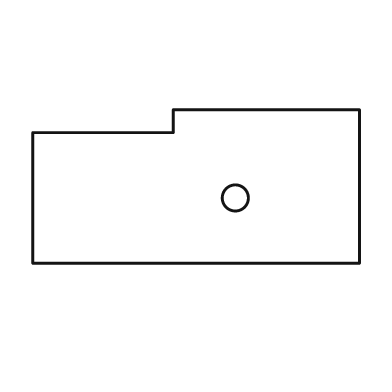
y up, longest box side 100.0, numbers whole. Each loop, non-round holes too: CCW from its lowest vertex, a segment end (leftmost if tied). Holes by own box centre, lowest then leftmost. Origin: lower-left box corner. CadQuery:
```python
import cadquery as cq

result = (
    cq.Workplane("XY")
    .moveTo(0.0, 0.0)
    .lineTo(100.0, 0.0)
    .lineTo(100.0, 47.0)
    .lineTo(43.0, 47.0)
    .lineTo(43.0, 40.0)
    .lineTo(0.0, 40.0)
    .close()
    .moveTo(62.0, 20.0)
    .circle(4.0)
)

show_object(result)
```